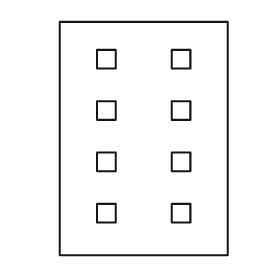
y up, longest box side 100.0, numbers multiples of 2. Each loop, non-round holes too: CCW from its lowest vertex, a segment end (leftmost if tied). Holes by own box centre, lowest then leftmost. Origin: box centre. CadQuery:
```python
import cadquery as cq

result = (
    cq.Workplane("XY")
    .moveTo(-36.0, -50.0)
    .lineTo(36.0, -50.0)
    .lineTo(36.0, 50.0)
    .lineTo(-36.0, 50.0)
    .close()
    .moveTo(-20.0, -36.0)
    .lineTo(-12.0, -36.0)
    .lineTo(-12.0, -28.0)
    .lineTo(-20.0, -28.0)
    .close()
    .moveTo(12.0, -36.0)
    .lineTo(20.0, -36.0)
    .lineTo(20.0, -28.0)
    .lineTo(12.0, -28.0)
    .close()
    .moveTo(-20.0, -14.0)
    .lineTo(-12.0, -14.0)
    .lineTo(-12.0, -6.0)
    .lineTo(-20.0, -6.0)
    .close()
    .moveTo(12.0, -14.0)
    .lineTo(20.0, -14.0)
    .lineTo(20.0, -6.0)
    .lineTo(12.0, -6.0)
    .close()
    .moveTo(-20.0, 8.0)
    .lineTo(-12.0, 8.0)
    .lineTo(-12.0, 16.0)
    .lineTo(-20.0, 16.0)
    .close()
    .moveTo(12.0, 8.0)
    .lineTo(20.0, 8.0)
    .lineTo(20.0, 16.0)
    .lineTo(12.0, 16.0)
    .close()
    .moveTo(-20.0, 30.0)
    .lineTo(-12.0, 30.0)
    .lineTo(-12.0, 38.0)
    .lineTo(-20.0, 38.0)
    .close()
    .moveTo(12.0, 30.0)
    .lineTo(20.0, 30.0)
    .lineTo(20.0, 38.0)
    .lineTo(12.0, 38.0)
    .close()
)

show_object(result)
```